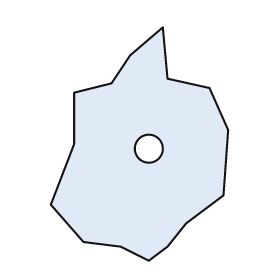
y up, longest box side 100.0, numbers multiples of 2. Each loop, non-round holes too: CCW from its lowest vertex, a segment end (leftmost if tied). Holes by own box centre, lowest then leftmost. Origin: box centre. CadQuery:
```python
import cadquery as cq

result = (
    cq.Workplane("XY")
    .moveTo(4.0, -50.0)
    .lineTo(12.0, -44.0)
    .lineTo(20.0, -34.0)
    .lineTo(36.0, -22.0)
    .lineTo(38.0, 6.0)
    .lineTo(30.0, 24.0)
    .lineTo(12.0, 28.0)
    .lineTo(10.0, 50.0)
    .lineTo(-4.0, 38.0)
    .lineTo(-12.0, 26.0)
    .lineTo(-28.0, 22.0)
    .lineTo(-28.0, 0.0)
    .lineTo(-38.0, -26.0)
    .lineTo(-24.0, -42.0)
    .lineTo(-8.0, -44.0)
    .close()
    .moveTo(4.0, -2.0)
    .circle(6.0)
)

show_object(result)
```